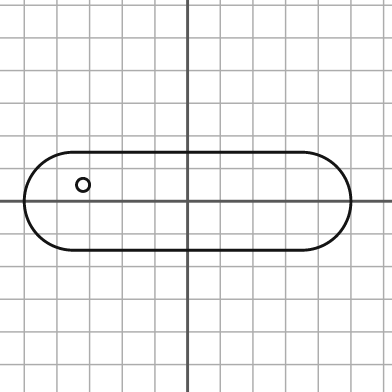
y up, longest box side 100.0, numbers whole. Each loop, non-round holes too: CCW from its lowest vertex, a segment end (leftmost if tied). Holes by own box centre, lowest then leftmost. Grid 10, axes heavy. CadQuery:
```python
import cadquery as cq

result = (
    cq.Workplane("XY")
    .moveTo(-35.0, -15.0)
    .lineTo(35.0, -15.0)
    .threePointArc((50.0, 0.0), (35.0, 15.0))
    .lineTo(-35.0, 15.0)
    .threePointArc((-50.0, 0.0), (-35.0, -15.0))
    .close()
    .moveTo(-32.0, 5.0)
    .circle(2.0)
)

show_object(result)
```